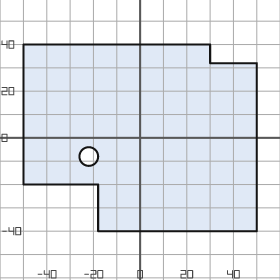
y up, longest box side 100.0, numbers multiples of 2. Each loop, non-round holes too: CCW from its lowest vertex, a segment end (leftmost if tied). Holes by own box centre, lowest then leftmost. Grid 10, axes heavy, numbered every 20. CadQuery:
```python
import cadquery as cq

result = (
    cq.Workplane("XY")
    .moveTo(-18.0, -40.0)
    .lineTo(50.0, -40.0)
    .lineTo(50.0, 32.0)
    .lineTo(30.0, 32.0)
    .lineTo(30.0, 40.0)
    .lineTo(-50.0, 40.0)
    .lineTo(-50.0, -20.0)
    .lineTo(-18.0, -20.0)
    .close()
    .moveTo(-22.0, -8.0)
    .circle(4.0)
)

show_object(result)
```